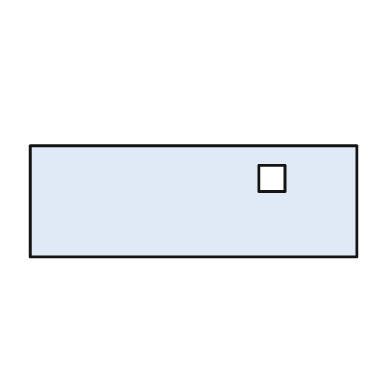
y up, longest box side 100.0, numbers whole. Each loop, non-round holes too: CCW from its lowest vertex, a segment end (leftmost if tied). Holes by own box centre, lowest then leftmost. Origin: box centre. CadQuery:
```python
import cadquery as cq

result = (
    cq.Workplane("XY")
    .moveTo(-50.0, -17.0)
    .lineTo(50.0, -17.0)
    .lineTo(50.0, 17.0)
    .lineTo(-50.0, 17.0)
    .close()
    .moveTo(20.0, 3.0)
    .lineTo(28.0, 3.0)
    .lineTo(28.0, 11.0)
    .lineTo(20.0, 11.0)
    .close()
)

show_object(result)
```